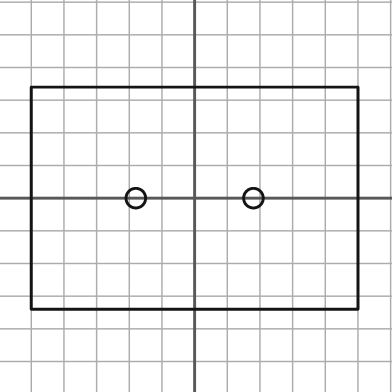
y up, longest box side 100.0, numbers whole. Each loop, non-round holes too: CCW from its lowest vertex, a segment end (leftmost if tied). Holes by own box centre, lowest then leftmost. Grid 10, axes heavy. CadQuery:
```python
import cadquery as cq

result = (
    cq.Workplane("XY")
    .moveTo(-50.0, -34.0)
    .lineTo(50.0, -34.0)
    .lineTo(50.0, 34.0)
    .lineTo(-50.0, 34.0)
    .close()
    .moveTo(-18.0, 0.0)
    .circle(3.0)
    .moveTo(18.0, 0.0)
    .circle(3.0)
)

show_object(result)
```